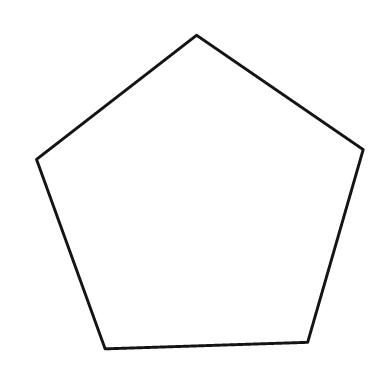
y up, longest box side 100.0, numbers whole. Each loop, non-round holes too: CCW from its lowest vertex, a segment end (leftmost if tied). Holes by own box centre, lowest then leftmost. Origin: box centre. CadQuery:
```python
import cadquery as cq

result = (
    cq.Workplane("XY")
    .moveTo(-29.0, -48.0)
    .lineTo(33.0, -46.0)
    .lineTo(50.0, 13.0)
    .lineTo(-1.0, 48.0)
    .lineTo(-50.0, 10.0)
    .close()
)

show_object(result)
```